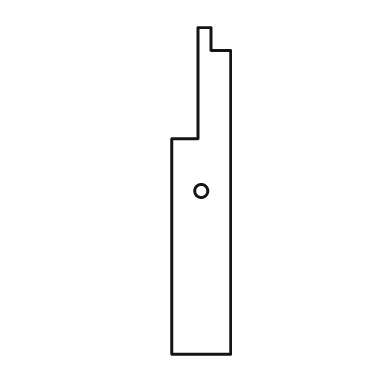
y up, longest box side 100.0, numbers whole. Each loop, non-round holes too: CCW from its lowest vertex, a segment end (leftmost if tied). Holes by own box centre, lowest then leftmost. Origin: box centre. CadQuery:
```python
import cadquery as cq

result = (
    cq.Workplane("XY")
    .moveTo(-9.0, -50.0)
    .lineTo(9.0, -50.0)
    .lineTo(9.0, 43.0)
    .lineTo(3.0, 43.0)
    .lineTo(3.0, 50.0)
    .lineTo(-1.0, 50.0)
    .lineTo(-1.0, 16.0)
    .lineTo(-9.0, 16.0)
    .close()
    .moveTo(0.0, 0.0)
    .circle(2.0)
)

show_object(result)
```